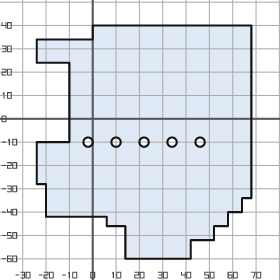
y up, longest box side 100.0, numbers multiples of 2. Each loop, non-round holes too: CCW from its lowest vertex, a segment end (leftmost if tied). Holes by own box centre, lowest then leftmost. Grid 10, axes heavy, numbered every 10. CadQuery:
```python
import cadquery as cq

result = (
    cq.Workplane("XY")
    .moveTo(14.0, -60.0)
    .lineTo(42.0, -60.0)
    .lineTo(42.0, -52.0)
    .lineTo(52.0, -52.0)
    .lineTo(52.0, -46.0)
    .lineTo(58.0, -46.0)
    .lineTo(58.0, -40.0)
    .lineTo(64.0, -40.0)
    .lineTo(64.0, -34.0)
    .lineTo(68.0, -34.0)
    .lineTo(68.0, 40.0)
    .lineTo(0.0, 40.0)
    .lineTo(0.0, 34.0)
    .lineTo(-24.0, 34.0)
    .lineTo(-24.0, 24.0)
    .lineTo(-10.0, 24.0)
    .lineTo(-10.0, -10.0)
    .lineTo(-24.0, -10.0)
    .lineTo(-24.0, -28.0)
    .lineTo(-20.0, -28.0)
    .lineTo(-20.0, -42.0)
    .lineTo(6.0, -42.0)
    .lineTo(6.0, -46.0)
    .lineTo(14.0, -46.0)
    .close()
    .moveTo(-2.0, -10.0)
    .circle(2.0)
    .moveTo(10.0, -10.0)
    .circle(2.0)
    .moveTo(22.0, -10.0)
    .circle(2.0)
    .moveTo(34.0, -10.0)
    .circle(2.0)
    .moveTo(46.0, -10.0)
    .circle(2.0)
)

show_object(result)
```